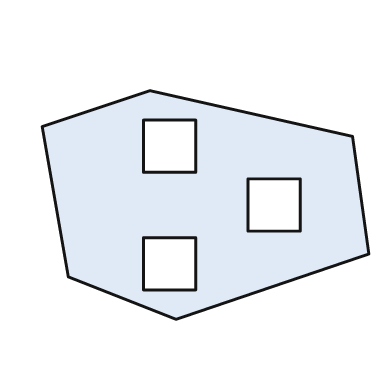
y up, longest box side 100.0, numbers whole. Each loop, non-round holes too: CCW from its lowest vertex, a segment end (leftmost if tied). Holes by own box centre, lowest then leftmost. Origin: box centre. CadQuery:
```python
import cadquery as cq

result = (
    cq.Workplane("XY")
    .moveTo(-9.0, -35.0)
    .lineTo(50.0, -15.0)
    .lineTo(45.0, 21.0)
    .lineTo(-17.0, 35.0)
    .lineTo(-50.0, 24.0)
    .lineTo(-42.0, -22.0)
    .close()
    .moveTo(-19.0, -26.0)
    .lineTo(-3.0, -26.0)
    .lineTo(-3.0, -10.0)
    .lineTo(-19.0, -10.0)
    .close()
    .moveTo(13.0, -8.0)
    .lineTo(29.0, -8.0)
    .lineTo(29.0, 8.0)
    .lineTo(13.0, 8.0)
    .close()
    .moveTo(-19.0, 10.0)
    .lineTo(-3.0, 10.0)
    .lineTo(-3.0, 26.0)
    .lineTo(-19.0, 26.0)
    .close()
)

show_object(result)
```